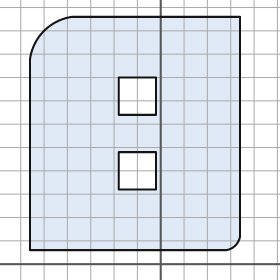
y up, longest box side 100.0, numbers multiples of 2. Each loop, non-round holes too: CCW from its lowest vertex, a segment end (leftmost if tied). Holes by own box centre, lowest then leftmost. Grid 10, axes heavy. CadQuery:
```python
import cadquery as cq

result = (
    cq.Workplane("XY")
    .moveTo(-56.0, 6.0)
    .lineTo(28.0, 6.0)
    .threePointArc((32.0, 8.0), (34.0, 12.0))
    .lineTo(34.0, 106.0)
    .lineTo(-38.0, 106.0)
    .threePointArc((-50.0, 100.0), (-56.0, 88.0))
    .close()
    .moveTo(-18.0, 32.0)
    .lineTo(-2.0, 32.0)
    .lineTo(-2.0, 48.0)
    .lineTo(-18.0, 48.0)
    .close()
    .moveTo(-18.0, 64.0)
    .lineTo(-2.0, 64.0)
    .lineTo(-2.0, 80.0)
    .lineTo(-18.0, 80.0)
    .close()
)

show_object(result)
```